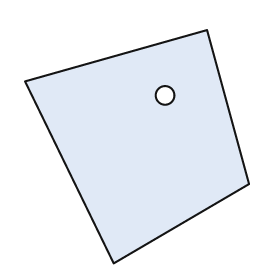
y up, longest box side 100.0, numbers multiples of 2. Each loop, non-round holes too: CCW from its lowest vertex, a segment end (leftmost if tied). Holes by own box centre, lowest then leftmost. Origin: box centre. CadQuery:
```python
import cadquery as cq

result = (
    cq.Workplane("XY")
    .moveTo(-10.0, -50.0)
    .lineTo(48.0, -16.0)
    .lineTo(30.0, 50.0)
    .lineTo(-48.0, 28.0)
    .close()
    .moveTo(12.0, 22.0)
    .circle(4.0)
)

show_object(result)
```